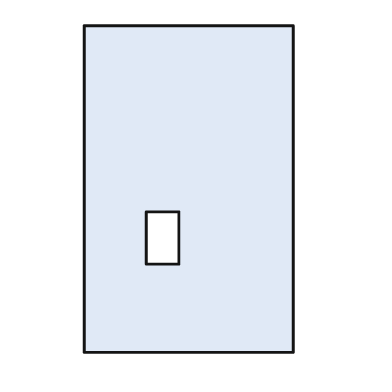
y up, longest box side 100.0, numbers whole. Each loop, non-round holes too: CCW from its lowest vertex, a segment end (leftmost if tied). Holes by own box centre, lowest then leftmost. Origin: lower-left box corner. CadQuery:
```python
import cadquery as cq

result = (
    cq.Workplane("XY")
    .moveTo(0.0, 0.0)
    .lineTo(64.0, 0.0)
    .lineTo(64.0, 100.0)
    .lineTo(0.0, 100.0)
    .close()
    .moveTo(19.0, 27.0)
    .lineTo(29.0, 27.0)
    .lineTo(29.0, 43.0)
    .lineTo(19.0, 43.0)
    .close()
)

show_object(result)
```